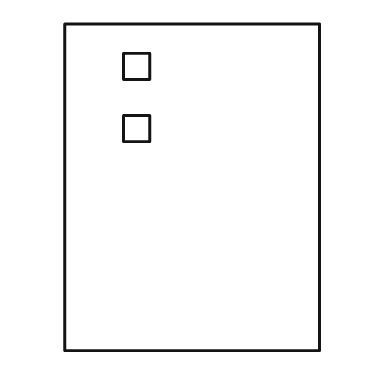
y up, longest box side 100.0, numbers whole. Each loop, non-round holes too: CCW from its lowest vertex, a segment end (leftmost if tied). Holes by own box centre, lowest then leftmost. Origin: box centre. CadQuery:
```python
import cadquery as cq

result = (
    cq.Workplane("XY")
    .moveTo(-39.0, -50.0)
    .lineTo(39.0, -50.0)
    .lineTo(39.0, 50.0)
    .lineTo(-39.0, 50.0)
    .close()
    .moveTo(-21.0, 14.0)
    .lineTo(-13.0, 14.0)
    .lineTo(-13.0, 22.0)
    .lineTo(-21.0, 22.0)
    .close()
    .moveTo(-21.0, 33.0)
    .lineTo(-13.0, 33.0)
    .lineTo(-13.0, 41.0)
    .lineTo(-21.0, 41.0)
    .close()
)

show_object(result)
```